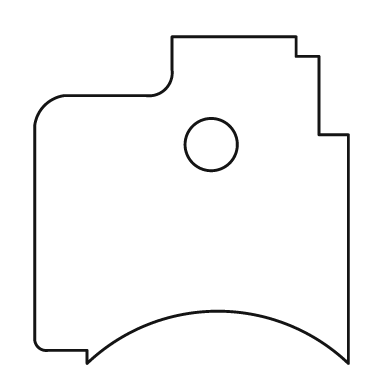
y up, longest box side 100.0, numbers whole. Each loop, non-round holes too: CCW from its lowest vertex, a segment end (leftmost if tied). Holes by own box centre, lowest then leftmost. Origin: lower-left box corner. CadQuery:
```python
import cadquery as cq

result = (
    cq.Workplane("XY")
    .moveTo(16.0, 0.0)
    .threePointArc((56.0, 16.0), (96.0, 0.0))
    .lineTo(96.0, 70.0)
    .lineTo(87.0, 70.0)
    .lineTo(87.0, 94.0)
    .lineTo(80.0, 94.0)
    .lineTo(80.0, 100.0)
    .lineTo(42.0, 100.0)
    .lineTo(42.0, 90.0)
    .threePointArc((40.0, 84.0), (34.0, 82.0))
    .lineTo(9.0, 82.0)
    .threePointArc((3.0, 79.0), (0.0, 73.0))
    .lineTo(0.0, 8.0)
    .threePointArc((1.0, 5.0), (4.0, 4.0))
    .lineTo(16.0, 4.0)
    .close()
    .moveTo(54.0, 67.0)
    .circle(8.0)
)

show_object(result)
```